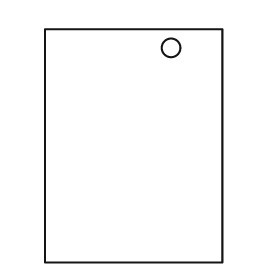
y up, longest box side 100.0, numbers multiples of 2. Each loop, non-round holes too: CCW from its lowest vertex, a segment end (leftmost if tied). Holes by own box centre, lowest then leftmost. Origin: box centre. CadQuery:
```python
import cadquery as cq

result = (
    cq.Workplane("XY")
    .moveTo(-38.0, -50.0)
    .lineTo(38.0, -50.0)
    .lineTo(38.0, 50.0)
    .lineTo(-38.0, 50.0)
    .close()
    .moveTo(16.0, 42.0)
    .circle(4.0)
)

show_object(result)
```